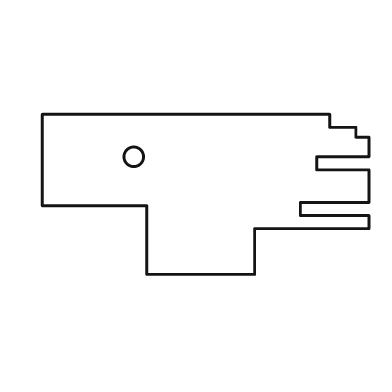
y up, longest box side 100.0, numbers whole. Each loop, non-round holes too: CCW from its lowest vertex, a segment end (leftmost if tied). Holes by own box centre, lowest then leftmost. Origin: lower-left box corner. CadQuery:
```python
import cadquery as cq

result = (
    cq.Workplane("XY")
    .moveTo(32.0, 0.0)
    .lineTo(65.0, 0.0)
    .lineTo(65.0, 14.0)
    .lineTo(100.0, 14.0)
    .lineTo(100.0, 18.0)
    .lineTo(79.0, 18.0)
    .lineTo(79.0, 22.0)
    .lineTo(100.0, 22.0)
    .lineTo(100.0, 32.0)
    .lineTo(84.0, 32.0)
    .lineTo(84.0, 36.0)
    .lineTo(100.0, 36.0)
    .lineTo(100.0, 42.0)
    .lineTo(96.0, 42.0)
    .lineTo(96.0, 45.0)
    .lineTo(88.0, 45.0)
    .lineTo(88.0, 49.0)
    .lineTo(0.0, 49.0)
    .lineTo(0.0, 21.0)
    .lineTo(32.0, 21.0)
    .close()
    .moveTo(28.0, 36.0)
    .circle(3.0)
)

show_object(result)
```